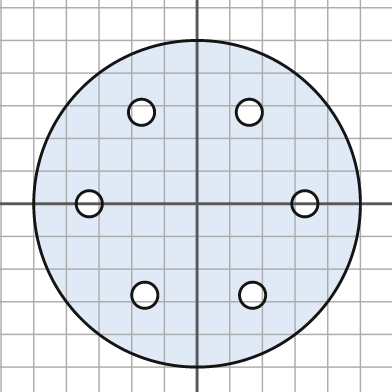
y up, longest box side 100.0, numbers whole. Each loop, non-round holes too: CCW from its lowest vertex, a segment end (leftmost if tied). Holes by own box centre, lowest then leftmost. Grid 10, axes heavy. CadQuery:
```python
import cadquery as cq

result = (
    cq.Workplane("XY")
    .moveTo(0.0, 0.0)
    .circle(50.0)
    .moveTo(-16.0, -28.0)
    .circle(4.0)
    .moveTo(17.0, -28.0)
    .circle(4.0)
    .moveTo(-33.0, 0.0)
    .circle(4.0)
    .moveTo(33.0, 0.0)
    .circle(4.0)
    .moveTo(-17.0, 28.0)
    .circle(4.0)
    .moveTo(16.0, 28.0)
    .circle(4.0)
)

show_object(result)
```